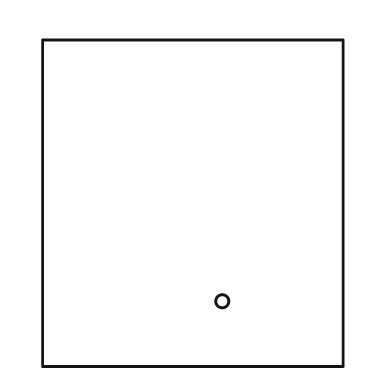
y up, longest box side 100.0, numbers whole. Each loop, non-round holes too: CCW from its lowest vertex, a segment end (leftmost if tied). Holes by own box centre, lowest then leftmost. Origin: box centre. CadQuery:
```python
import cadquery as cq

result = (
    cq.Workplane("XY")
    .moveTo(-46.0, -50.0)
    .lineTo(46.0, -50.0)
    .lineTo(46.0, 50.0)
    .lineTo(-46.0, 50.0)
    .close()
    .moveTo(9.0, -30.0)
    .circle(2.0)
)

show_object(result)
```